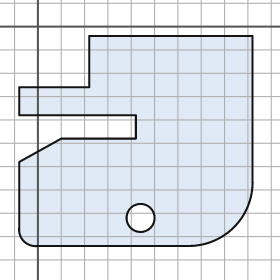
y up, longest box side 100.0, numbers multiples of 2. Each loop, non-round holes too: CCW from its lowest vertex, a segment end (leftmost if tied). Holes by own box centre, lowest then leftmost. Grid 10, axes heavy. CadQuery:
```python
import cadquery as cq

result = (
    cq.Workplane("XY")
    .moveTo(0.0, -94.0)
    .lineTo(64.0, -94.0)
    .threePointArc((84.0, -86.0), (92.0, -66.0))
    .lineTo(92.0, -4.0)
    .lineTo(22.0, -4.0)
    .lineTo(22.0, -26.0)
    .lineTo(-8.0, -26.0)
    .lineTo(-8.0, -38.0)
    .lineTo(42.0, -38.0)
    .lineTo(42.0, -48.0)
    .lineTo(10.0, -48.0)
    .lineTo(-8.0, -58.0)
    .lineTo(-8.0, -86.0)
    .threePointArc((-6.0, -92.0), (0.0, -94.0))
    .close()
    .moveTo(44.0, -82.0)
    .circle(6.0)
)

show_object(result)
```